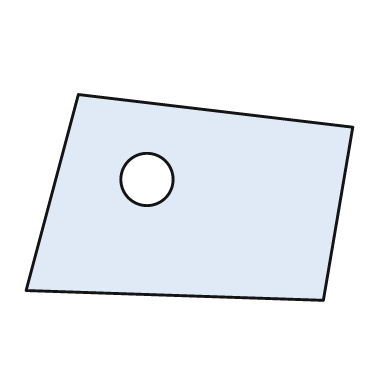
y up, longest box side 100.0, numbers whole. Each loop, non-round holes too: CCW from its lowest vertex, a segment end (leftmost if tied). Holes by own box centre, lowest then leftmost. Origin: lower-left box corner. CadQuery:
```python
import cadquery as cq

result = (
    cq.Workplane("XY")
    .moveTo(91.0, 0.0)
    .lineTo(100.0, 53.0)
    .lineTo(16.0, 63.0)
    .lineTo(0.0, 3.0)
    .close()
    .moveTo(37.0, 37.0)
    .circle(8.0)
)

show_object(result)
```